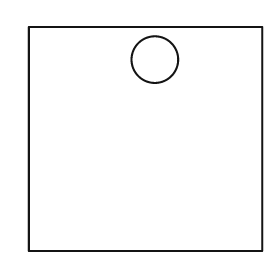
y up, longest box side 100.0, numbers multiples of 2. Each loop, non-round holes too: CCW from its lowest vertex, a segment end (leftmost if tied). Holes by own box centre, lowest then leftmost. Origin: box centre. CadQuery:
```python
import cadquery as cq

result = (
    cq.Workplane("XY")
    .moveTo(-50.0, -48.0)
    .lineTo(50.0, -48.0)
    .lineTo(50.0, 48.0)
    .lineTo(-50.0, 48.0)
    .close()
    .moveTo(4.0, 34.0)
    .circle(10.0)
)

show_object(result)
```